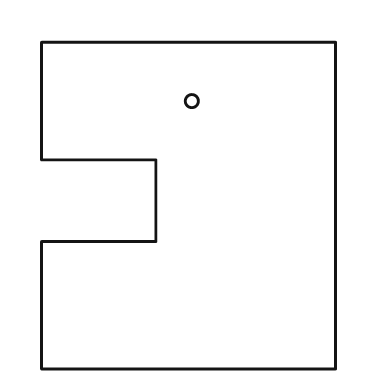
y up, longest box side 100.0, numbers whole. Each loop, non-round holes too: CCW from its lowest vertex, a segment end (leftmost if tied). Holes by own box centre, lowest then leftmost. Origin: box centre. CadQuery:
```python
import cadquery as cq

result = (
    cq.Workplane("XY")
    .moveTo(-45.0, -50.0)
    .lineTo(45.0, -50.0)
    .lineTo(45.0, 50.0)
    .lineTo(-45.0, 50.0)
    .lineTo(-45.0, 14.0)
    .lineTo(-10.0, 14.0)
    .lineTo(-10.0, -11.0)
    .lineTo(-45.0, -11.0)
    .close()
    .moveTo(1.0, 32.0)
    .circle(2.0)
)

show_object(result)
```